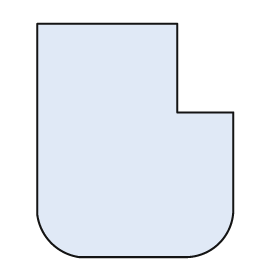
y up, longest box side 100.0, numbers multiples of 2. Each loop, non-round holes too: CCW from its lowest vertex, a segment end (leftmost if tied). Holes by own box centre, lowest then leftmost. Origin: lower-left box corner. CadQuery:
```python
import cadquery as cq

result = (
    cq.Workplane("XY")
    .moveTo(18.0, 0.0)
    .lineTo(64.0, 0.0)
    .threePointArc((78.0, 6.0), (84.0, 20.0))
    .lineTo(84.0, 62.0)
    .lineTo(60.0, 62.0)
    .lineTo(60.0, 100.0)
    .lineTo(0.0, 100.0)
    .lineTo(0.0, 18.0)
    .threePointArc((6.0, 6.0), (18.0, 0.0))
    .close()
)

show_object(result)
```